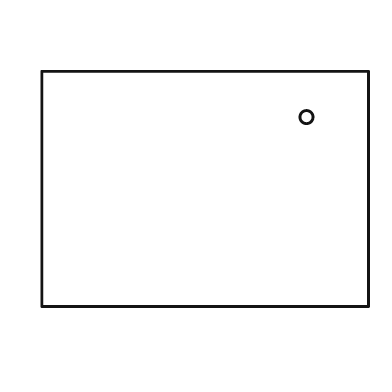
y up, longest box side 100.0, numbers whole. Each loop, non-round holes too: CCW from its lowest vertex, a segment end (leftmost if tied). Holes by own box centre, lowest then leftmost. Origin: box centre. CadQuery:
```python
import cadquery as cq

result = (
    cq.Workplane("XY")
    .moveTo(-50.0, -36.0)
    .lineTo(50.0, -36.0)
    .lineTo(50.0, 36.0)
    .lineTo(-50.0, 36.0)
    .close()
    .moveTo(31.0, 22.0)
    .circle(2.0)
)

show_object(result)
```